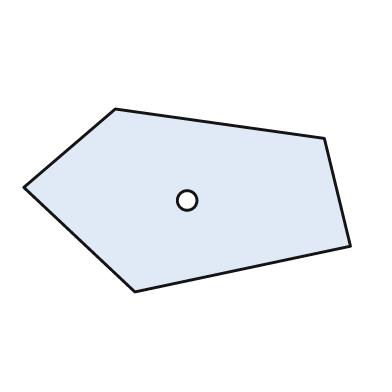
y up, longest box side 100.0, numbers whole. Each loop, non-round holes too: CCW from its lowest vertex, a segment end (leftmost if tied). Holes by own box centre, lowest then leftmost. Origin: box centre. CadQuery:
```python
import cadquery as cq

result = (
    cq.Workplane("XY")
    .moveTo(-16.0, -28.0)
    .lineTo(50.0, -14.0)
    .lineTo(42.0, 19.0)
    .lineTo(-22.0, 28.0)
    .lineTo(-50.0, 4.0)
    .close()
    .moveTo(0.0, 0.0)
    .circle(3.0)
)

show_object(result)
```